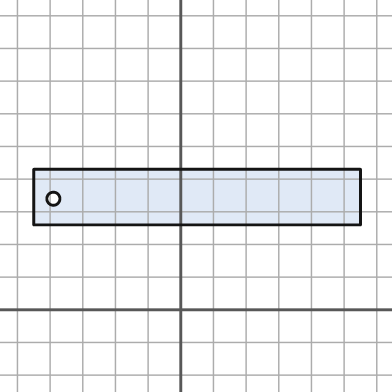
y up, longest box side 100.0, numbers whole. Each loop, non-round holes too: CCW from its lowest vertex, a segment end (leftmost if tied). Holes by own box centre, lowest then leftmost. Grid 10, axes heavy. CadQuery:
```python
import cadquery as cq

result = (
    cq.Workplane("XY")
    .moveTo(-45.0, 26.0)
    .lineTo(55.0, 26.0)
    .lineTo(55.0, 43.0)
    .lineTo(-45.0, 43.0)
    .close()
    .moveTo(-39.0, 34.0)
    .circle(2.0)
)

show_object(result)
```